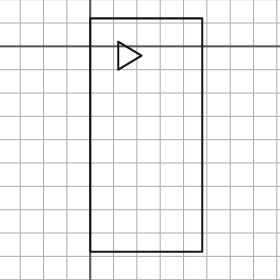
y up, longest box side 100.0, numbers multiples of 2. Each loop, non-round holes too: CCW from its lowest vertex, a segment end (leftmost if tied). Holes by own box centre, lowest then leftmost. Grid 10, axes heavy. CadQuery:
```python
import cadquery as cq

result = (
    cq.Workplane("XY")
    .moveTo(0.0, -88.0)
    .lineTo(48.0, -88.0)
    .lineTo(48.0, 12.0)
    .lineTo(0.0, 12.0)
    .close()
    .moveTo(12.0, -10.0)
    .lineTo(22.0, -4.0)
    .lineTo(12.0, 2.0)
    .close()
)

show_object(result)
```